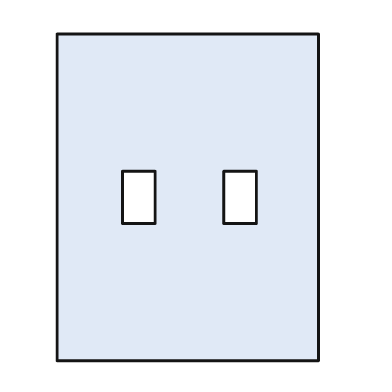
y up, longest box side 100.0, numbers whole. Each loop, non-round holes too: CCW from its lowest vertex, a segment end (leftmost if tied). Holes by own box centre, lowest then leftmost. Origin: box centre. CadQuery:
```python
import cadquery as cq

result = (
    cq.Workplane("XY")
    .moveTo(-40.0, -50.0)
    .lineTo(40.0, -50.0)
    .lineTo(40.0, 50.0)
    .lineTo(-40.0, 50.0)
    .close()
    .moveTo(-20.0, -8.0)
    .lineTo(-10.0, -8.0)
    .lineTo(-10.0, 8.0)
    .lineTo(-20.0, 8.0)
    .close()
    .moveTo(11.0, -8.0)
    .lineTo(21.0, -8.0)
    .lineTo(21.0, 8.0)
    .lineTo(11.0, 8.0)
    .close()
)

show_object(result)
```